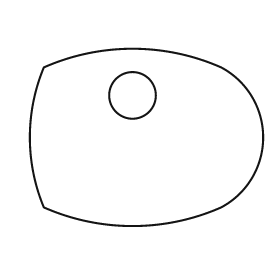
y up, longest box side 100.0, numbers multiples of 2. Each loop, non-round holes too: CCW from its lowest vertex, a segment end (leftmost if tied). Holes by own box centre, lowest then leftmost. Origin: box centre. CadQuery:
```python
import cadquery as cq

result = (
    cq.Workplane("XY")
    .moveTo(-44.0, -30.0)
    .threePointArc((-6.0, -38.0), (32.0, -30.0))
    .threePointArc((50.0, 0.0), (32.0, 30.0))
    .threePointArc((-6.0, 38.0), (-44.0, 30.0))
    .threePointArc((-50.0, 0.0), (-44.0, -30.0))
    .close()
    .moveTo(-6.0, 18.0)
    .circle(10.0)
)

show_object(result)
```